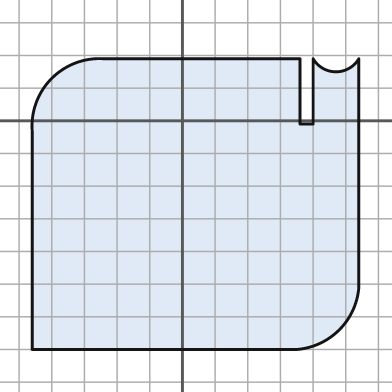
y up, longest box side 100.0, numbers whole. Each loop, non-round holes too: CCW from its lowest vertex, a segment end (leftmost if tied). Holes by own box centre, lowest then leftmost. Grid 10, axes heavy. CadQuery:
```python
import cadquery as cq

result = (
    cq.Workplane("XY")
    .moveTo(-46.0, -70.0)
    .lineTo(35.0, -70.0)
    .threePointArc((48.0, -64.0), (54.0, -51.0))
    .lineTo(54.0, 19.0)
    .threePointArc((47.0, 15.0), (40.0, 19.0))
    .lineTo(40.0, -1.0)
    .lineTo(36.0, -1.0)
    .lineTo(36.0, 19.0)
    .lineTo(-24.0, 19.0)
    .threePointArc((-40.0, 13.0), (-46.0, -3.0))
    .close()
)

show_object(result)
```